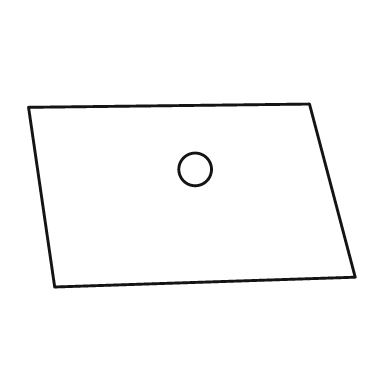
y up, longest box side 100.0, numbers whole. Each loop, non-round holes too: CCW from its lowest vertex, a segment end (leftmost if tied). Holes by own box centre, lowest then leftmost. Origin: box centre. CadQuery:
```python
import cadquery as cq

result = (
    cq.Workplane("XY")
    .moveTo(-42.0, -28.0)
    .lineTo(50.0, -25.0)
    .lineTo(36.0, 28.0)
    .lineTo(-50.0, 27.0)
    .close()
    .moveTo(1.0, 8.0)
    .circle(5.0)
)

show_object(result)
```